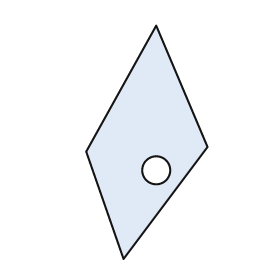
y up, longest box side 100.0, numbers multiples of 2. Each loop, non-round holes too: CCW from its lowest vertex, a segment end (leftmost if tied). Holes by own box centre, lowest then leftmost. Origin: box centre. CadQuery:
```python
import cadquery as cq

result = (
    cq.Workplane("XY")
    .moveTo(-10.0, -50.0)
    .lineTo(26.0, -2.0)
    .lineTo(4.0, 50.0)
    .lineTo(-26.0, -4.0)
    .close()
    .moveTo(4.0, -12.0)
    .circle(6.0)
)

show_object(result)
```